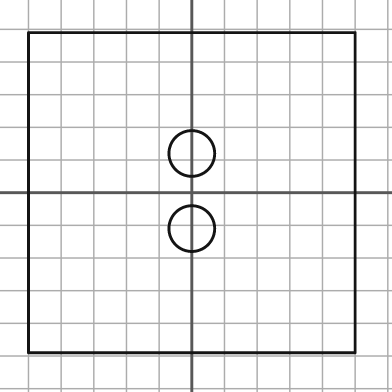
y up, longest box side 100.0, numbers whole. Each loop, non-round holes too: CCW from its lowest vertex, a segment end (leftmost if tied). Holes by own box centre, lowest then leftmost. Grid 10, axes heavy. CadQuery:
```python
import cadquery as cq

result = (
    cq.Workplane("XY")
    .moveTo(-50.0, -49.0)
    .lineTo(50.0, -49.0)
    .lineTo(50.0, 49.0)
    .lineTo(-50.0, 49.0)
    .close()
    .moveTo(0.0, -11.0)
    .circle(7.0)
    .moveTo(0.0, 12.0)
    .circle(7.0)
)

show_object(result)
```